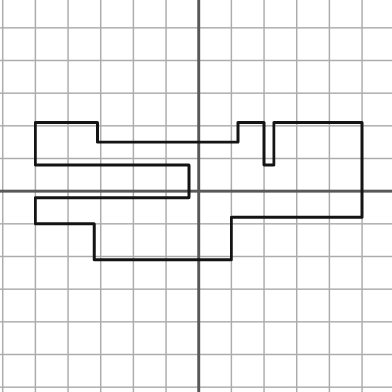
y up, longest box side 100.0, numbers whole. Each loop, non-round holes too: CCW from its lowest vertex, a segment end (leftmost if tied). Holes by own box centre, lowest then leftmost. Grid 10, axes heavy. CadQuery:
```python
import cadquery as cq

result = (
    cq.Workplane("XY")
    .moveTo(-32.0, -21.0)
    .lineTo(10.0, -21.0)
    .lineTo(10.0, -8.0)
    .lineTo(50.0, -8.0)
    .lineTo(50.0, 21.0)
    .lineTo(23.0, 21.0)
    .lineTo(23.0, 8.0)
    .lineTo(20.0, 8.0)
    .lineTo(20.0, 21.0)
    .lineTo(12.0, 21.0)
    .lineTo(12.0, 15.0)
    .lineTo(-31.0, 15.0)
    .lineTo(-31.0, 21.0)
    .lineTo(-50.0, 21.0)
    .lineTo(-50.0, 8.0)
    .lineTo(-3.0, 8.0)
    .lineTo(-3.0, -2.0)
    .lineTo(-50.0, -2.0)
    .lineTo(-50.0, -10.0)
    .lineTo(-32.0, -10.0)
    .close()
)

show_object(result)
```